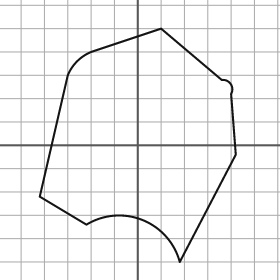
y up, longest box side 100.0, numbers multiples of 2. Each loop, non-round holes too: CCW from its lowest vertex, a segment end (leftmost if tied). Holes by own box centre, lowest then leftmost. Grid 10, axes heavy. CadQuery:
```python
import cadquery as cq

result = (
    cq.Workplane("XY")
    .moveTo(18.0, -50.0)
    .lineTo(42.0, -4.0)
    .lineTo(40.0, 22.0)
    .threePointArc((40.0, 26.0), (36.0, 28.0))
    .lineTo(10.0, 50.0)
    .lineTo(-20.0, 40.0)
    .threePointArc((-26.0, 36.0), (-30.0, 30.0))
    .lineTo(-42.0, -22.0)
    .lineTo(-22.0, -34.0)
    .threePointArc((2.0, -32.0), (18.0, -50.0))
    .close()
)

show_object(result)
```